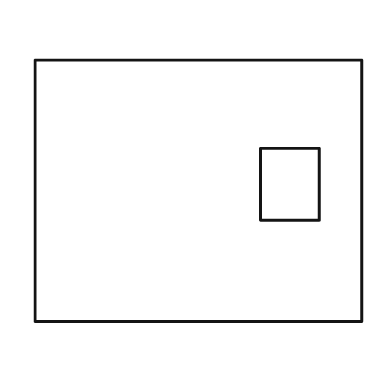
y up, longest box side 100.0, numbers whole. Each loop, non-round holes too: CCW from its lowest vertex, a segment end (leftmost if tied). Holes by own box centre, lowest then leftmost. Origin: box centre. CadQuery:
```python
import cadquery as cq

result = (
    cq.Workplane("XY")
    .moveTo(-50.0, -40.0)
    .lineTo(50.0, -40.0)
    .lineTo(50.0, 40.0)
    .lineTo(-50.0, 40.0)
    .close()
    .moveTo(19.0, -9.0)
    .lineTo(37.0, -9.0)
    .lineTo(37.0, 13.0)
    .lineTo(19.0, 13.0)
    .close()
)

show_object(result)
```